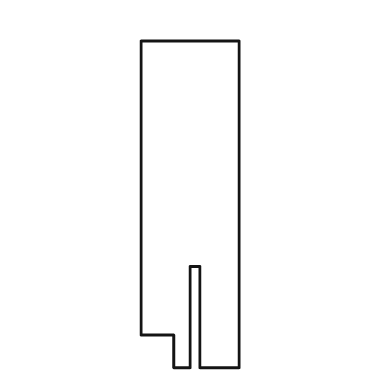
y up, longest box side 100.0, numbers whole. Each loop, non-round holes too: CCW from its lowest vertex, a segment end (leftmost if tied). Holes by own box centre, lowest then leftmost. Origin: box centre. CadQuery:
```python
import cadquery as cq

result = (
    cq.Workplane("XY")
    .moveTo(-5.0, -50.0)
    .lineTo(0.0, -50.0)
    .lineTo(0.0, -19.0)
    .lineTo(3.0, -19.0)
    .lineTo(3.0, -50.0)
    .lineTo(15.0, -50.0)
    .lineTo(15.0, 50.0)
    .lineTo(-15.0, 50.0)
    .lineTo(-15.0, -40.0)
    .lineTo(-5.0, -40.0)
    .close()
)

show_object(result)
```